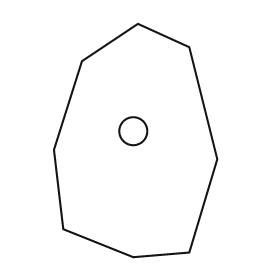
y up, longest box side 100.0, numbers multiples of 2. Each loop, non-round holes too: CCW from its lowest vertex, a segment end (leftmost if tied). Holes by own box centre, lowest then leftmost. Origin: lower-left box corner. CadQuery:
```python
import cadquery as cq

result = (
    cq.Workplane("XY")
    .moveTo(34.0, 0.0)
    .lineTo(58.0, 2.0)
    .lineTo(70.0, 42.0)
    .lineTo(58.0, 90.0)
    .lineTo(36.0, 100.0)
    .lineTo(12.0, 84.0)
    .lineTo(0.0, 46.0)
    .lineTo(4.0, 12.0)
    .close()
    .moveTo(34.0, 54.0)
    .circle(6.0)
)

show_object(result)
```